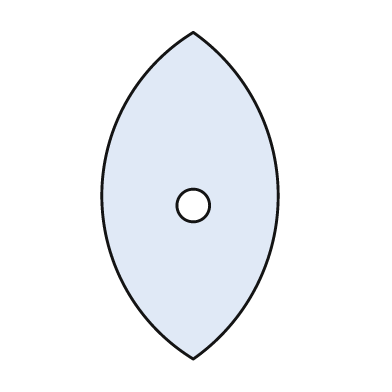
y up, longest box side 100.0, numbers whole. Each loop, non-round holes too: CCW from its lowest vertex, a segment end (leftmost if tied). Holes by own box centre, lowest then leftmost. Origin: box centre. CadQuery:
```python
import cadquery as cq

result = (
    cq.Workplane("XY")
    .moveTo(1.0, -50.0)
    .threePointArc((27.0, 0.0), (1.0, 50.0))
    .threePointArc((-27.0, 0.0), (1.0, -50.0))
    .close()
    .moveTo(1.0, -3.0)
    .circle(5.0)
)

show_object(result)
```